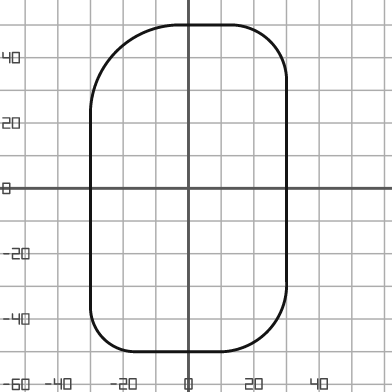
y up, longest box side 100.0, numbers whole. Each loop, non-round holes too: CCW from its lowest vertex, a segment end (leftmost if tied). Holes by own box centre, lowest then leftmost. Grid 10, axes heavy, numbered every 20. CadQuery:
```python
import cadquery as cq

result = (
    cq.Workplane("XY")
    .moveTo(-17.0, -50.0)
    .lineTo(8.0, -50.0)
    .threePointArc((24.0, -44.0), (30.0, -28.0))
    .lineTo(30.0, 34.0)
    .threePointArc((25.0, 45.0), (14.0, 50.0))
    .lineTo(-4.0, 50.0)
    .threePointArc((-22.0, 42.0), (-30.0, 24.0))
    .lineTo(-30.0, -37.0)
    .threePointArc((-26.0, -46.0), (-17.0, -50.0))
    .close()
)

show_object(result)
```